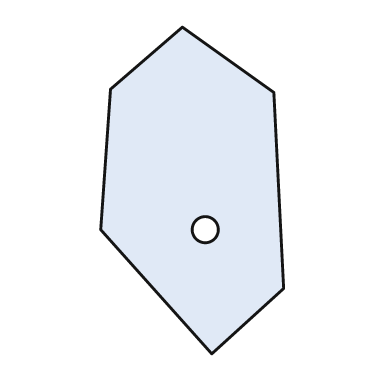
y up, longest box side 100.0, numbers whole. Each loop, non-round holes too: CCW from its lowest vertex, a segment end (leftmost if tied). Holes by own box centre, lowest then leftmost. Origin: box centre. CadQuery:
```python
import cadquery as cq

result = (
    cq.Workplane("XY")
    .moveTo(6.0, -50.0)
    .lineTo(28.0, -30.0)
    .lineTo(25.0, 30.0)
    .lineTo(-3.0, 50.0)
    .lineTo(-25.0, 31.0)
    .lineTo(-28.0, -12.0)
    .close()
    .moveTo(4.0, -12.0)
    .circle(4.0)
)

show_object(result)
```